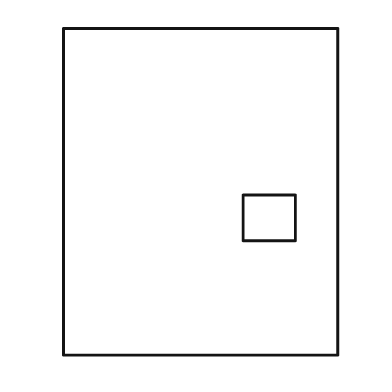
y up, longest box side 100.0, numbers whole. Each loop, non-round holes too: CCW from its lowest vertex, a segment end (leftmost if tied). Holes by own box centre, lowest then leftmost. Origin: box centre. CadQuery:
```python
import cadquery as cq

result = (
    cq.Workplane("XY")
    .moveTo(-42.0, -50.0)
    .lineTo(42.0, -50.0)
    .lineTo(42.0, 50.0)
    .lineTo(-42.0, 50.0)
    .close()
    .moveTo(13.0, -15.0)
    .lineTo(29.0, -15.0)
    .lineTo(29.0, -1.0)
    .lineTo(13.0, -1.0)
    .close()
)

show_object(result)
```